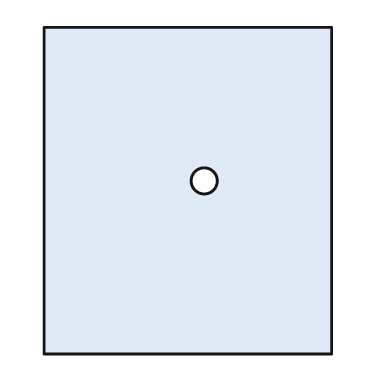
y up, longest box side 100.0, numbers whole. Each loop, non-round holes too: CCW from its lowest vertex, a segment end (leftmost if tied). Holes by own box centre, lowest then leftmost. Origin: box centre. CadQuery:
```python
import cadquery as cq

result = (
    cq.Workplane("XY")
    .moveTo(-44.0, -50.0)
    .lineTo(44.0, -50.0)
    .lineTo(44.0, 50.0)
    .lineTo(-44.0, 50.0)
    .close()
    .moveTo(5.0, 3.0)
    .circle(4.0)
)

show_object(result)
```